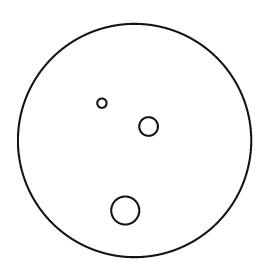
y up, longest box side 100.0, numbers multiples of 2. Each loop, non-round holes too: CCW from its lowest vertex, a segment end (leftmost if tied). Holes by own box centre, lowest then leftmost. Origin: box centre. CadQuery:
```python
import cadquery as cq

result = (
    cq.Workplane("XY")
    .moveTo(0.0, 0.0)
    .circle(50.0)
    .moveTo(-4.0, -30.0)
    .circle(6.0)
    .moveTo(6.0, 6.0)
    .circle(4.0)
    .moveTo(-14.0, 16.0)
    .circle(2.0)
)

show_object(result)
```